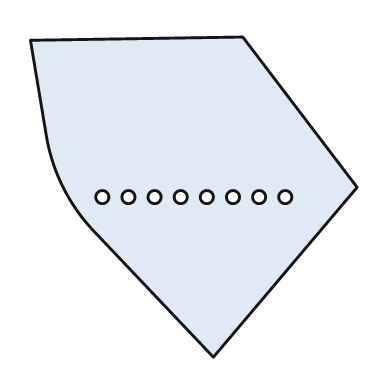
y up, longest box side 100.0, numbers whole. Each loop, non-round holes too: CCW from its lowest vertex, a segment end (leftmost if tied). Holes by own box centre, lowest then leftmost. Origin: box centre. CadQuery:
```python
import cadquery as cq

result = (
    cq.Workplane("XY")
    .moveTo(6.0, -49.0)
    .lineTo(50.0, 3.0)
    .lineTo(15.0, 49.0)
    .lineTo(-50.0, 48.0)
    .lineTo(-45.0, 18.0)
    .threePointArc((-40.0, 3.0), (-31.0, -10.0))
    .close()
    .moveTo(-28.0, 0.0)
    .circle(2.0)
    .moveTo(-20.0, 0.0)
    .circle(2.0)
    .moveTo(-12.0, 0.0)
    .circle(2.0)
    .moveTo(-4.0, 0.0)
    .circle(2.0)
    .moveTo(4.0, 0.0)
    .circle(2.0)
    .moveTo(12.0, 0.0)
    .circle(2.0)
    .moveTo(20.0, 0.0)
    .circle(2.0)
    .moveTo(28.0, 0.0)
    .circle(2.0)
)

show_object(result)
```